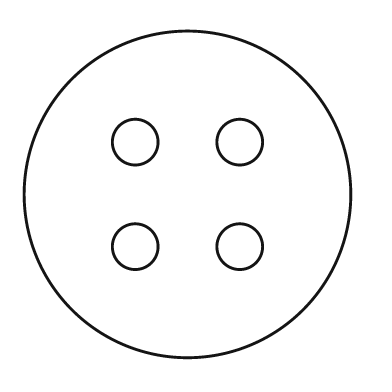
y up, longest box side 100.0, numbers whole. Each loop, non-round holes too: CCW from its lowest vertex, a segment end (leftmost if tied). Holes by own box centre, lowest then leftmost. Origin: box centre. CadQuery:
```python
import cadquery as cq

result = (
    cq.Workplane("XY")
    .moveTo(0.0, 0.0)
    .circle(50.0)
    .moveTo(-16.0, -16.0)
    .circle(7.0)
    .moveTo(16.0, -16.0)
    .circle(7.0)
    .moveTo(-16.0, 16.0)
    .circle(7.0)
    .moveTo(16.0, 16.0)
    .circle(7.0)
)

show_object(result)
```